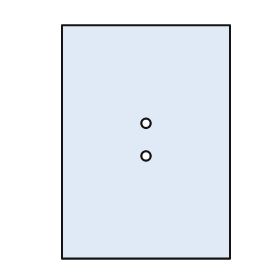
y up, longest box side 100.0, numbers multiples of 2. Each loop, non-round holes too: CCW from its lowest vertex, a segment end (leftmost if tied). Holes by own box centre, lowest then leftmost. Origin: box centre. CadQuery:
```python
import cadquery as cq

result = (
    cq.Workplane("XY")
    .moveTo(-36.0, -50.0)
    .lineTo(36.0, -50.0)
    .lineTo(36.0, 50.0)
    .lineTo(-36.0, 50.0)
    .close()
    .moveTo(0.0, -6.0)
    .circle(2.0)
    .moveTo(0.0, 8.0)
    .circle(2.0)
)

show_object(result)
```